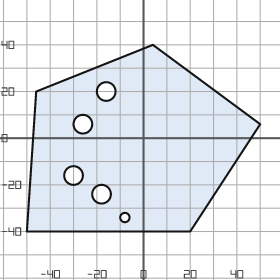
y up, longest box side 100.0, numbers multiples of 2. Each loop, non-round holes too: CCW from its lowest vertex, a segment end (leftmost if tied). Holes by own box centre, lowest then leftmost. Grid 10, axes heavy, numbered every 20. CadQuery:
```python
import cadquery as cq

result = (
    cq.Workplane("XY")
    .moveTo(-50.0, -40.0)
    .lineTo(20.0, -40.0)
    .lineTo(50.0, 6.0)
    .lineTo(4.0, 40.0)
    .lineTo(-46.0, 20.0)
    .close()
    .moveTo(-8.0, -34.0)
    .circle(2.0)
    .moveTo(-18.0, -24.0)
    .circle(4.0)
    .moveTo(-30.0, -16.0)
    .circle(4.0)
    .moveTo(-26.0, 6.0)
    .circle(4.0)
    .moveTo(-16.0, 20.0)
    .circle(4.0)
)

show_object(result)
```